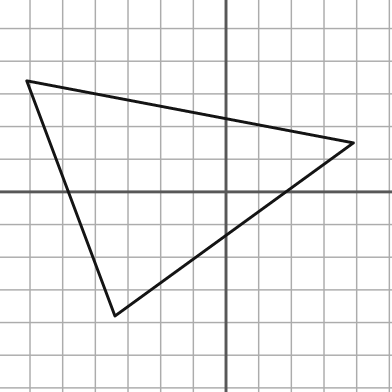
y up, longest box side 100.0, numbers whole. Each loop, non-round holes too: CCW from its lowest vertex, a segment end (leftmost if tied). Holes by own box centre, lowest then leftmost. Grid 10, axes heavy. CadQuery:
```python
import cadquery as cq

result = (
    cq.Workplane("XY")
    .moveTo(-34.0, -38.0)
    .lineTo(39.0, 15.0)
    .lineTo(-61.0, 34.0)
    .close()
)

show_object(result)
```